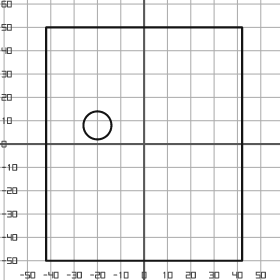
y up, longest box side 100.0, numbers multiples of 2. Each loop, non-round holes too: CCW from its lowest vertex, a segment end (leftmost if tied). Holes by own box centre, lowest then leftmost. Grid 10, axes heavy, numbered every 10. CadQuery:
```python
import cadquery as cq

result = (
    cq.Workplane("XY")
    .moveTo(-42.0, -50.0)
    .lineTo(42.0, -50.0)
    .lineTo(42.0, 50.0)
    .lineTo(-42.0, 50.0)
    .close()
    .moveTo(-20.0, 8.0)
    .circle(6.0)
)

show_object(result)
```